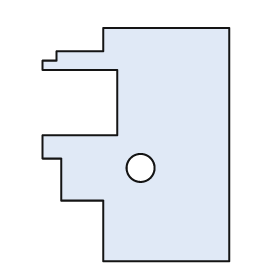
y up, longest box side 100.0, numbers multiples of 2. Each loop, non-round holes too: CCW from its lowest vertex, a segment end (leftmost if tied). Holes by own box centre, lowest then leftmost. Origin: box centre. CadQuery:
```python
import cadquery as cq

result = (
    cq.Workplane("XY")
    .moveTo(-14.0, -50.0)
    .lineTo(40.0, -50.0)
    .lineTo(40.0, 50.0)
    .lineTo(-14.0, 50.0)
    .lineTo(-14.0, 40.0)
    .lineTo(-34.0, 40.0)
    .lineTo(-34.0, 36.0)
    .lineTo(-40.0, 36.0)
    .lineTo(-40.0, 32.0)
    .lineTo(-8.0, 32.0)
    .lineTo(-8.0, 4.0)
    .lineTo(-40.0, 4.0)
    .lineTo(-40.0, -6.0)
    .lineTo(-32.0, -6.0)
    .lineTo(-32.0, -24.0)
    .lineTo(-14.0, -24.0)
    .close()
    .moveTo(2.0, -10.0)
    .circle(6.0)
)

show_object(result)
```